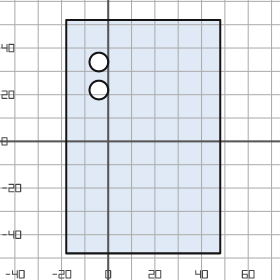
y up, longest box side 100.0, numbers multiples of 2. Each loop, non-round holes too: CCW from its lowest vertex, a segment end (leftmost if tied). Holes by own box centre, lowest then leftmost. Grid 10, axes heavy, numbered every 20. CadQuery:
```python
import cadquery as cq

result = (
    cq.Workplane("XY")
    .moveTo(-18.0, -48.0)
    .lineTo(48.0, -48.0)
    .lineTo(48.0, 52.0)
    .lineTo(-18.0, 52.0)
    .close()
    .moveTo(-4.0, 22.0)
    .circle(4.0)
    .moveTo(-4.0, 34.0)
    .circle(4.0)
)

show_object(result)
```